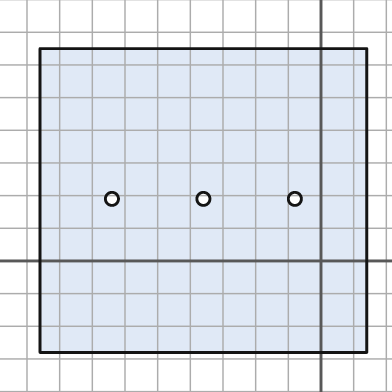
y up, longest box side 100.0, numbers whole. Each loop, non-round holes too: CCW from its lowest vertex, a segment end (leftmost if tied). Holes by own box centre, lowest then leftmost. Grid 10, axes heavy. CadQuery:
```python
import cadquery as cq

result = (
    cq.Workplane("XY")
    .moveTo(-86.0, -28.0)
    .lineTo(14.0, -28.0)
    .lineTo(14.0, 65.0)
    .lineTo(-86.0, 65.0)
    .close()
    .moveTo(-64.0, 19.0)
    .circle(2.0)
    .moveTo(-36.0, 19.0)
    .circle(2.0)
    .moveTo(-8.0, 19.0)
    .circle(2.0)
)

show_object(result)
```